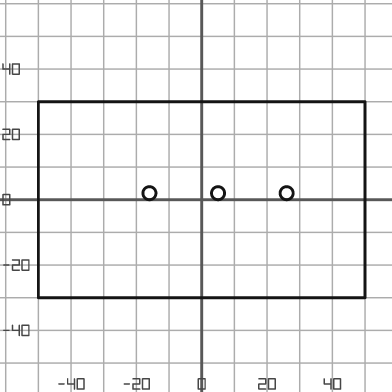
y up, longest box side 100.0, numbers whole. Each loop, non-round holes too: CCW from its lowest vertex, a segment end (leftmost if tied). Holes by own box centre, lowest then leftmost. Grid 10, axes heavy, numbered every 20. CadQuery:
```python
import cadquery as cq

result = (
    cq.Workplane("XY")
    .moveTo(-50.0, -30.0)
    .lineTo(50.0, -30.0)
    .lineTo(50.0, 30.0)
    .lineTo(-50.0, 30.0)
    .close()
    .moveTo(-16.0, 2.0)
    .circle(2.0)
    .moveTo(5.0, 2.0)
    .circle(2.0)
    .moveTo(26.0, 2.0)
    .circle(2.0)
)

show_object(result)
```